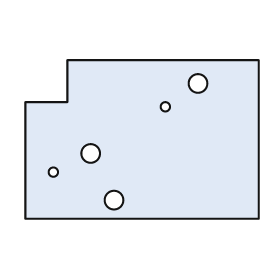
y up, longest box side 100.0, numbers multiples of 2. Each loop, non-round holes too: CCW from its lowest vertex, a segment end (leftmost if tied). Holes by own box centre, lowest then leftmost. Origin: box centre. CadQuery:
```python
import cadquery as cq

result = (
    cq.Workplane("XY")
    .moveTo(-50.0, -34.0)
    .lineTo(50.0, -34.0)
    .lineTo(50.0, 34.0)
    .lineTo(-32.0, 34.0)
    .lineTo(-32.0, 16.0)
    .lineTo(-50.0, 16.0)
    .close()
    .moveTo(-12.0, -26.0)
    .circle(4.0)
    .moveTo(-38.0, -14.0)
    .circle(2.0)
    .moveTo(-22.0, -6.0)
    .circle(4.0)
    .moveTo(10.0, 14.0)
    .circle(2.0)
    .moveTo(24.0, 24.0)
    .circle(4.0)
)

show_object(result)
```